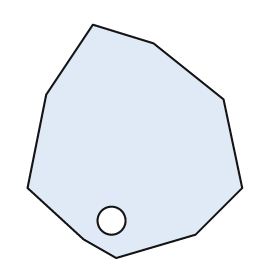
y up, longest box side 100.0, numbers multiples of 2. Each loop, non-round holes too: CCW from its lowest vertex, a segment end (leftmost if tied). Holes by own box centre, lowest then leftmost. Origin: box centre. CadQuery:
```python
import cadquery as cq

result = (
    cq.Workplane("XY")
    .moveTo(-8.0, -50.0)
    .lineTo(26.0, -40.0)
    .lineTo(46.0, -20.0)
    .lineTo(38.0, 18.0)
    .lineTo(8.0, 42.0)
    .lineTo(-18.0, 50.0)
    .lineTo(-38.0, 20.0)
    .lineTo(-46.0, -20.0)
    .lineTo(-22.0, -42.0)
    .close()
    .moveTo(-10.0, -34.0)
    .circle(6.0)
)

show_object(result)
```